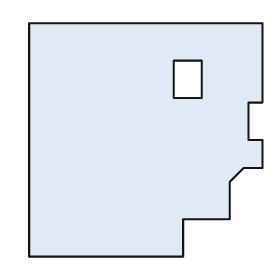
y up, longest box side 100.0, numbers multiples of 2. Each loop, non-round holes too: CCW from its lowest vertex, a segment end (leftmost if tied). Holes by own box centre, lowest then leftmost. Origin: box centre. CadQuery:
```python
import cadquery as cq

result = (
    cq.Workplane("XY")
    .moveTo(-50.0, -50.0)
    .lineTo(16.0, -50.0)
    .lineTo(16.0, -34.0)
    .lineTo(36.0, -34.0)
    .lineTo(36.0, -18.0)
    .lineTo(42.0, -12.0)
    .lineTo(50.0, -12.0)
    .lineTo(50.0, 0.0)
    .lineTo(44.0, 0.0)
    .lineTo(44.0, 16.0)
    .lineTo(50.0, 16.0)
    .lineTo(50.0, 50.0)
    .lineTo(-50.0, 50.0)
    .close()
    .moveTo(12.0, 18.0)
    .lineTo(24.0, 18.0)
    .lineTo(24.0, 34.0)
    .lineTo(12.0, 34.0)
    .close()
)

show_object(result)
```